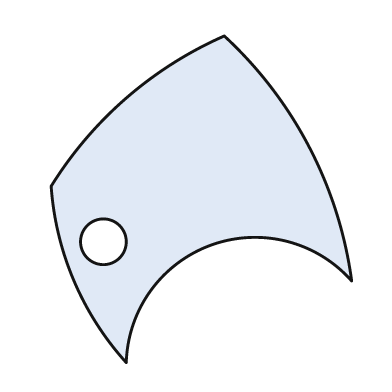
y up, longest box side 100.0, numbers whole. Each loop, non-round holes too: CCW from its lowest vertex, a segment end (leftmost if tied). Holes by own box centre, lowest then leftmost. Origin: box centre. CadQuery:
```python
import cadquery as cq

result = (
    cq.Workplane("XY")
    .moveTo(-23.0, -50.0)
    .threePointArc((3.0, -14.0), (46.0, -25.0))
    .threePointArc((33.0, 16.0), (7.0, 50.0))
    .threePointArc((-23.0, 31.0), (-46.0, 4.0))
    .threePointArc((-39.0, -25.0), (-23.0, -50.0))
    .close()
    .moveTo(-30.0, -13.0)
    .circle(7.0)
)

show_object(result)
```